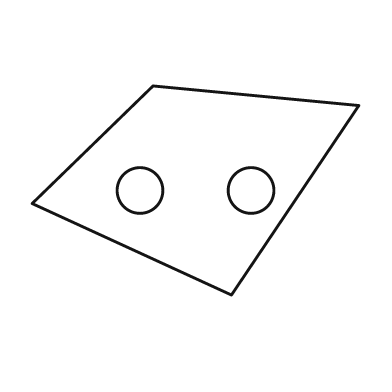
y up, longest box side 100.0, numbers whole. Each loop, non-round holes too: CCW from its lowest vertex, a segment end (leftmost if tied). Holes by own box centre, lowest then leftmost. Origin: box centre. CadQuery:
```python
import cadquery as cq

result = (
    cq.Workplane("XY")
    .moveTo(11.0, -32.0)
    .lineTo(50.0, 26.0)
    .lineTo(-13.0, 32.0)
    .lineTo(-50.0, -4.0)
    .close()
    .moveTo(-17.0, 0.0)
    .circle(7.0)
    .moveTo(17.0, 0.0)
    .circle(7.0)
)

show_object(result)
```